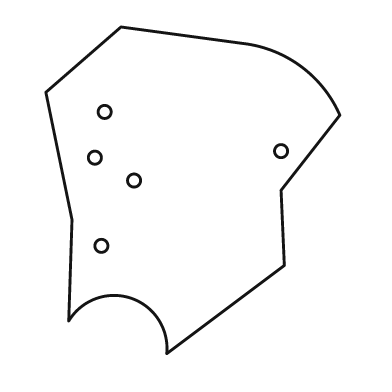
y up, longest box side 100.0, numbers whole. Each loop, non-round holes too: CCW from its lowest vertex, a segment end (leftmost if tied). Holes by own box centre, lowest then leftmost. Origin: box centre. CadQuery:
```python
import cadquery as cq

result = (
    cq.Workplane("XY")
    .moveTo(-8.0, -50.0)
    .lineTo(28.0, -23.0)
    .lineTo(27.0, 0.0)
    .lineTo(45.0, 23.0)
    .threePointArc((33.0, 38.0), (15.0, 45.0))
    .lineTo(-22.0, 50.0)
    .lineTo(-45.0, 30.0)
    .lineTo(-37.0, -9.0)
    .lineTo(-38.0, -40.0)
    .threePointArc((-19.0, -33.0), (-8.0, -50.0))
    .close()
    .moveTo(-28.0, -17.0)
    .circle(2.0)
    .moveTo(-18.0, 3.0)
    .circle(2.0)
    .moveTo(-30.0, 10.0)
    .circle(2.0)
    .moveTo(27.0, 12.0)
    .circle(2.0)
    .moveTo(-27.0, 24.0)
    .circle(2.0)
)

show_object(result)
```